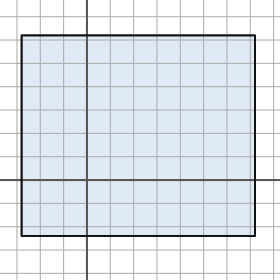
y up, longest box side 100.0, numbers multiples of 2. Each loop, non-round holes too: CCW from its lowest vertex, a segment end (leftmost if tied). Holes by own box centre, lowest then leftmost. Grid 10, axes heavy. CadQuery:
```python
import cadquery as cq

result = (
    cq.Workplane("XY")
    .moveTo(-28.0, -24.0)
    .lineTo(72.0, -24.0)
    .lineTo(72.0, 62.0)
    .lineTo(-28.0, 62.0)
    .close()
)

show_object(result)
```